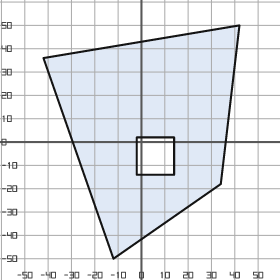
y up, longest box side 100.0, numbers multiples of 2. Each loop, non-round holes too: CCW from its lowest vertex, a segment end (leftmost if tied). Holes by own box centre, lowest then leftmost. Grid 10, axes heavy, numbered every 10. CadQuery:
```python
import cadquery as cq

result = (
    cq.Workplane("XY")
    .moveTo(-12.0, -50.0)
    .lineTo(34.0, -18.0)
    .lineTo(42.0, 50.0)
    .lineTo(-42.0, 36.0)
    .close()
    .moveTo(-2.0, -14.0)
    .lineTo(14.0, -14.0)
    .lineTo(14.0, 2.0)
    .lineTo(-2.0, 2.0)
    .close()
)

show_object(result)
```